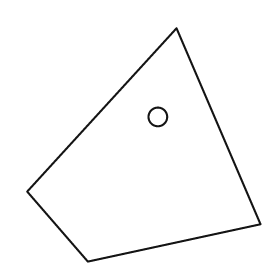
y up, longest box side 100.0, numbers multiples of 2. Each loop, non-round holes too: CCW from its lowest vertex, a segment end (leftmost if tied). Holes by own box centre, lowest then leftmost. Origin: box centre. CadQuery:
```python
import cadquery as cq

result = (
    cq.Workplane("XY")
    .moveTo(-24.0, -50.0)
    .lineTo(50.0, -34.0)
    .lineTo(14.0, 50.0)
    .lineTo(-50.0, -20.0)
    .close()
    .moveTo(6.0, 12.0)
    .circle(4.0)
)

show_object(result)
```